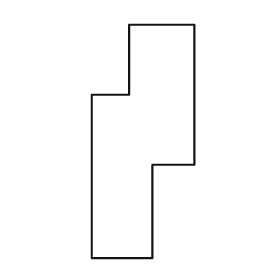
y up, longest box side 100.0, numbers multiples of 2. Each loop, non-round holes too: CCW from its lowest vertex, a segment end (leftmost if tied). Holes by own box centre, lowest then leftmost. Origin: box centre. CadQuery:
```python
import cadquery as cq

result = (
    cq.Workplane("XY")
    .moveTo(-22.0, -50.0)
    .lineTo(4.0, -50.0)
    .lineTo(4.0, -10.0)
    .lineTo(22.0, -10.0)
    .lineTo(22.0, 50.0)
    .lineTo(-6.0, 50.0)
    .lineTo(-6.0, 20.0)
    .lineTo(-22.0, 20.0)
    .close()
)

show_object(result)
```